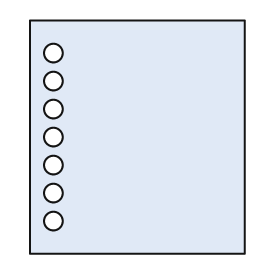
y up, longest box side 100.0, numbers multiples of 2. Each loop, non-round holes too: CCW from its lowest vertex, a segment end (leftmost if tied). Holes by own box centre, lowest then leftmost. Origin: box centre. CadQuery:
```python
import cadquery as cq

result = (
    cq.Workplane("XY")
    .moveTo(-46.0, -50.0)
    .lineTo(46.0, -50.0)
    .lineTo(46.0, 50.0)
    .lineTo(-46.0, 50.0)
    .close()
    .moveTo(-36.0, -36.0)
    .circle(4.0)
    .moveTo(-36.0, -24.0)
    .circle(4.0)
    .moveTo(-36.0, -12.0)
    .circle(4.0)
    .moveTo(-36.0, 0.0)
    .circle(4.0)
    .moveTo(-36.0, 12.0)
    .circle(4.0)
    .moveTo(-36.0, 24.0)
    .circle(4.0)
    .moveTo(-36.0, 36.0)
    .circle(4.0)
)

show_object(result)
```